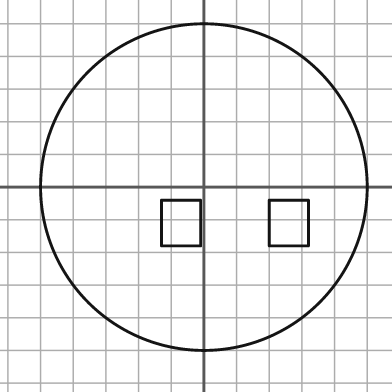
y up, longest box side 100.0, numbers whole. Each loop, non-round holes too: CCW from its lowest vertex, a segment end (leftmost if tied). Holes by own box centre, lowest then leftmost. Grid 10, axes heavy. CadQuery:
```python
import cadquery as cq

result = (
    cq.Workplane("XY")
    .moveTo(0.0, 0.0)
    .circle(50.0)
    .moveTo(-13.0, -18.0)
    .lineTo(-1.0, -18.0)
    .lineTo(-1.0, -4.0)
    .lineTo(-13.0, -4.0)
    .close()
    .moveTo(20.0, -18.0)
    .lineTo(32.0, -18.0)
    .lineTo(32.0, -4.0)
    .lineTo(20.0, -4.0)
    .close()
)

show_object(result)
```